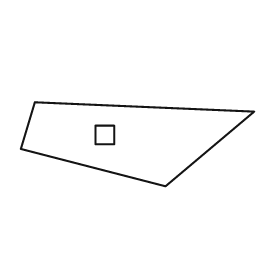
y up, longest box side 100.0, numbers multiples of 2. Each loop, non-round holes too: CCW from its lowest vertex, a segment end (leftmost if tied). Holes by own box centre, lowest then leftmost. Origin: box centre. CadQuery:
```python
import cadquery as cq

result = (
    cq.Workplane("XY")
    .moveTo(12.0, -18.0)
    .lineTo(50.0, 14.0)
    .lineTo(-44.0, 18.0)
    .lineTo(-50.0, -2.0)
    .close()
    .moveTo(-18.0, 0.0)
    .lineTo(-10.0, 0.0)
    .lineTo(-10.0, 8.0)
    .lineTo(-18.0, 8.0)
    .close()
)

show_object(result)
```